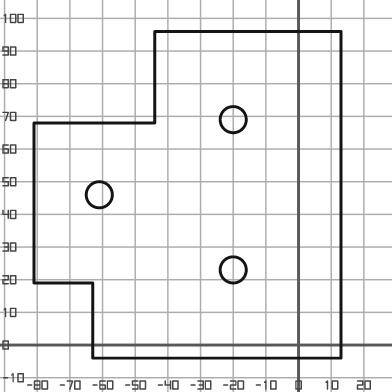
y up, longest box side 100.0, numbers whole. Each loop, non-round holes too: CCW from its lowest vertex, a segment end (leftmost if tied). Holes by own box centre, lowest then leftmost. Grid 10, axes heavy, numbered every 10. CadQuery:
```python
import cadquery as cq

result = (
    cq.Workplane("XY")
    .moveTo(-63.0, -4.0)
    .lineTo(13.0, -4.0)
    .lineTo(13.0, 96.0)
    .lineTo(-44.0, 96.0)
    .lineTo(-44.0, 68.0)
    .lineTo(-81.0, 68.0)
    .lineTo(-81.0, 19.0)
    .lineTo(-63.0, 19.0)
    .close()
    .moveTo(-20.0, 23.0)
    .circle(4.0)
    .moveTo(-61.0, 46.0)
    .circle(4.0)
    .moveTo(-20.0, 69.0)
    .circle(4.0)
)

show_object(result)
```